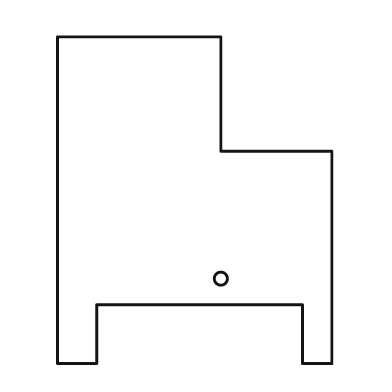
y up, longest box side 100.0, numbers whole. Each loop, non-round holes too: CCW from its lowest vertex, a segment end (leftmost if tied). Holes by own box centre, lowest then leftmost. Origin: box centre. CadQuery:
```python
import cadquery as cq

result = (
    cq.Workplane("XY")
    .moveTo(-42.0, -50.0)
    .lineTo(-30.0, -50.0)
    .lineTo(-30.0, -32.0)
    .lineTo(33.0, -32.0)
    .lineTo(33.0, -50.0)
    .lineTo(42.0, -50.0)
    .lineTo(42.0, 15.0)
    .lineTo(8.0, 15.0)
    .lineTo(8.0, 50.0)
    .lineTo(-42.0, 50.0)
    .close()
    .moveTo(8.0, -24.0)
    .circle(2.0)
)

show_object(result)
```